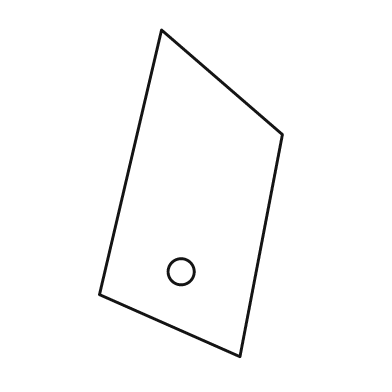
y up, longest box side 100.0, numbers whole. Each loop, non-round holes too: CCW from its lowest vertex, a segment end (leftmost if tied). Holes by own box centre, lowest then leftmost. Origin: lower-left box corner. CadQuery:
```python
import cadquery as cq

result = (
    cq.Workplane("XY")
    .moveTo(43.0, 0.0)
    .lineTo(56.0, 68.0)
    .lineTo(19.0, 100.0)
    .lineTo(0.0, 19.0)
    .close()
    .moveTo(25.0, 26.0)
    .circle(4.0)
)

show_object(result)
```